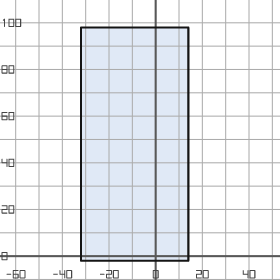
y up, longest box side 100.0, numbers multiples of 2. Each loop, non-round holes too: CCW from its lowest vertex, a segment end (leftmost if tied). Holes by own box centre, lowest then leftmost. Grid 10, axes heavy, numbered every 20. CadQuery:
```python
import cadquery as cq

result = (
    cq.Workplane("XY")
    .moveTo(-32.0, -2.0)
    .lineTo(14.0, -2.0)
    .lineTo(14.0, 98.0)
    .lineTo(-32.0, 98.0)
    .close()
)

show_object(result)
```